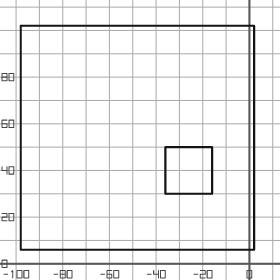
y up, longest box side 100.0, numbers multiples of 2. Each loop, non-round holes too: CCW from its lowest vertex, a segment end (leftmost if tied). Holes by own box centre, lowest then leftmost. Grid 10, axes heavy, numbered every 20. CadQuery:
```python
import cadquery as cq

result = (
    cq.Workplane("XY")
    .moveTo(-98.0, 6.0)
    .lineTo(2.0, 6.0)
    .lineTo(2.0, 102.0)
    .lineTo(-98.0, 102.0)
    .close()
    .moveTo(-36.0, 30.0)
    .lineTo(-16.0, 30.0)
    .lineTo(-16.0, 50.0)
    .lineTo(-36.0, 50.0)
    .close()
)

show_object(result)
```